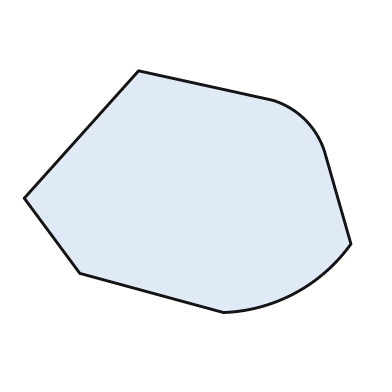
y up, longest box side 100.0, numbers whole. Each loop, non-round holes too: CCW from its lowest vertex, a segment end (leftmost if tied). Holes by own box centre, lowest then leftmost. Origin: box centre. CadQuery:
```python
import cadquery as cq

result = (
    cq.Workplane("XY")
    .moveTo(11.0, -37.0)
    .threePointArc((33.0, -31.0), (50.0, -16.0))
    .lineTo(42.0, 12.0)
    .threePointArc((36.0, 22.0), (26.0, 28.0))
    .lineTo(-15.0, 37.0)
    .lineTo(-50.0, -2.0)
    .lineTo(-33.0, -25.0)
    .close()
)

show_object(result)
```